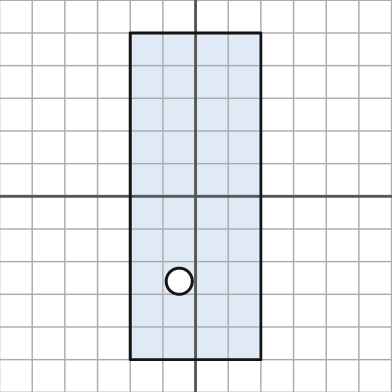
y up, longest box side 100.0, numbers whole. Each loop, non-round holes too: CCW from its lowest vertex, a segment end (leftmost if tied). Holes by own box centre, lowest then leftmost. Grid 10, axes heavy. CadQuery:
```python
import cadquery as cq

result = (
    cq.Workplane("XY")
    .moveTo(-20.0, -50.0)
    .lineTo(20.0, -50.0)
    .lineTo(20.0, 50.0)
    .lineTo(-20.0, 50.0)
    .close()
    .moveTo(-5.0, -26.0)
    .circle(4.0)
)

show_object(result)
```